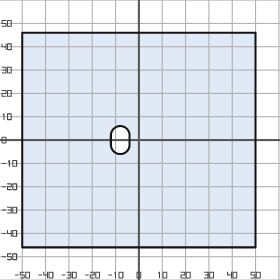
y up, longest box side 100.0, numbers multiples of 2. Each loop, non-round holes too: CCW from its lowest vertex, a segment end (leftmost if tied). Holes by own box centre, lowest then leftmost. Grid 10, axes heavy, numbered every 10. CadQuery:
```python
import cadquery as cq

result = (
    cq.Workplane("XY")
    .moveTo(-50.0, -46.0)
    .lineTo(50.0, -46.0)
    .lineTo(50.0, 46.0)
    .lineTo(-50.0, 46.0)
    .close()
    .moveTo(-12.0, -2.0)
    .threePointArc((-8.0, -6.0), (-4.0, -2.0))
    .lineTo(-4.0, 2.0)
    .threePointArc((-8.0, 6.0), (-12.0, 2.0))
    .close()
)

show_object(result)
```